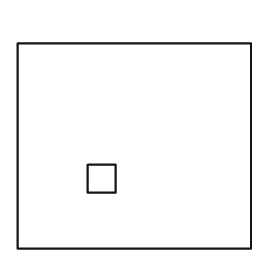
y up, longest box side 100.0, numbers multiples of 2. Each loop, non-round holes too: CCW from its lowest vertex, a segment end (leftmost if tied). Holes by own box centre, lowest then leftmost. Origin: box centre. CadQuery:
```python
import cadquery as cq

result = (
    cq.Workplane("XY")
    .moveTo(-50.0, -44.0)
    .lineTo(50.0, -44.0)
    .lineTo(50.0, 44.0)
    .lineTo(-50.0, 44.0)
    .close()
    .moveTo(-20.0, -20.0)
    .lineTo(-8.0, -20.0)
    .lineTo(-8.0, -8.0)
    .lineTo(-20.0, -8.0)
    .close()
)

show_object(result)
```